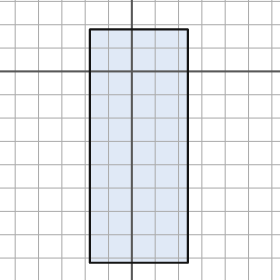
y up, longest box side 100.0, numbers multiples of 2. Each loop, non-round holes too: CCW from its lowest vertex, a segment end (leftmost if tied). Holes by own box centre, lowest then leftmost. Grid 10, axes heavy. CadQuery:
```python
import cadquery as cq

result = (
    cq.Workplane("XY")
    .moveTo(-18.0, -82.0)
    .lineTo(24.0, -82.0)
    .lineTo(24.0, 18.0)
    .lineTo(-18.0, 18.0)
    .close()
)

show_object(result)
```